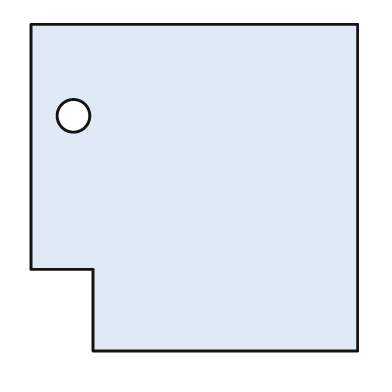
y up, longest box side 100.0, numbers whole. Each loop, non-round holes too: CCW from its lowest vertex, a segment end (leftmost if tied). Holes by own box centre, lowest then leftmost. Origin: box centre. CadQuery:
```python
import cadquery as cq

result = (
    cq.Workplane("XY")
    .moveTo(-31.0, -50.0)
    .lineTo(50.0, -50.0)
    .lineTo(50.0, 50.0)
    .lineTo(-50.0, 50.0)
    .lineTo(-50.0, -25.0)
    .lineTo(-31.0, -25.0)
    .close()
    .moveTo(-37.0, 22.0)
    .circle(5.0)
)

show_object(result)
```